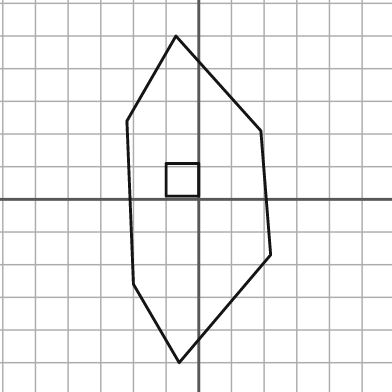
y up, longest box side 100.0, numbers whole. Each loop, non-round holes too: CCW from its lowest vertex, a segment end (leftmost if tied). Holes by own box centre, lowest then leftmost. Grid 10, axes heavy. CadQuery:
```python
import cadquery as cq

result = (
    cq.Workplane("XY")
    .moveTo(-6.0, -50.0)
    .lineTo(22.0, -17.0)
    .lineTo(19.0, 21.0)
    .lineTo(-7.0, 50.0)
    .lineTo(-22.0, 24.0)
    .lineTo(-20.0, -26.0)
    .close()
    .moveTo(-10.0, 1.0)
    .lineTo(0.0, 1.0)
    .lineTo(0.0, 11.0)
    .lineTo(-10.0, 11.0)
    .close()
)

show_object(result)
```